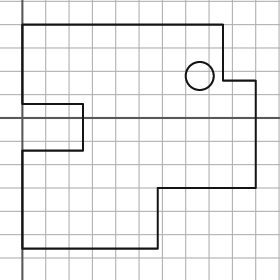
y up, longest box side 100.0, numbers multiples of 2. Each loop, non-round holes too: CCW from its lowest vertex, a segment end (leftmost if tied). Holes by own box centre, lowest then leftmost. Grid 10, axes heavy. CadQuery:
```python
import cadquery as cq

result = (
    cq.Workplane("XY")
    .moveTo(0.0, -56.0)
    .lineTo(58.0, -56.0)
    .lineTo(58.0, -30.0)
    .lineTo(100.0, -30.0)
    .lineTo(100.0, 16.0)
    .lineTo(86.0, 16.0)
    .lineTo(86.0, 40.0)
    .lineTo(0.0, 40.0)
    .lineTo(0.0, 6.0)
    .lineTo(26.0, 6.0)
    .lineTo(26.0, -14.0)
    .lineTo(0.0, -14.0)
    .close()
    .moveTo(76.0, 18.0)
    .circle(6.0)
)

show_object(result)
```